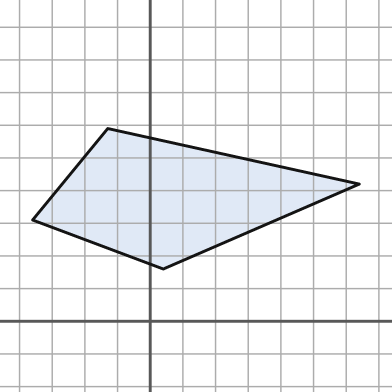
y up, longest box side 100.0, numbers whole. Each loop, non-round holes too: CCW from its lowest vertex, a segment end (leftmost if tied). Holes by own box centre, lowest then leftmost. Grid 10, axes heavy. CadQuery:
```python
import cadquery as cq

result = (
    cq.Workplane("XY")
    .moveTo(4.0, 16.0)
    .lineTo(64.0, 42.0)
    .lineTo(-13.0, 59.0)
    .lineTo(-36.0, 31.0)
    .close()
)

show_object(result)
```